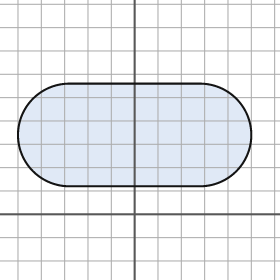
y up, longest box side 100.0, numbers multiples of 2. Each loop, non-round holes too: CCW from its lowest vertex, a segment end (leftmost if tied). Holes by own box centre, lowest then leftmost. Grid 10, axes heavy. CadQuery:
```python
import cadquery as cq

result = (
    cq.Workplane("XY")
    .moveTo(-28.0, 12.0)
    .lineTo(28.0, 12.0)
    .threePointArc((50.0, 34.0), (28.0, 56.0))
    .lineTo(-28.0, 56.0)
    .threePointArc((-50.0, 34.0), (-28.0, 12.0))
    .close()
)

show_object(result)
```